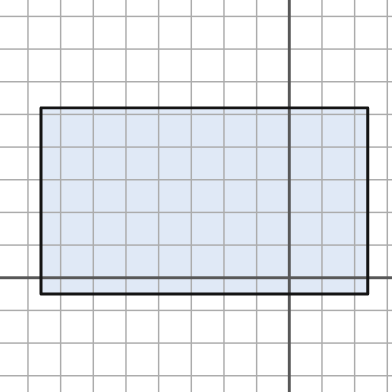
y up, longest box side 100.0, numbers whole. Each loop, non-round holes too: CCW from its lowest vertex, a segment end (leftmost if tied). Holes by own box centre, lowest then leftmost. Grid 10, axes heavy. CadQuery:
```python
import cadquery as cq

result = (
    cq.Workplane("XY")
    .moveTo(-76.0, -5.0)
    .lineTo(24.0, -5.0)
    .lineTo(24.0, 52.0)
    .lineTo(-76.0, 52.0)
    .close()
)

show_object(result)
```